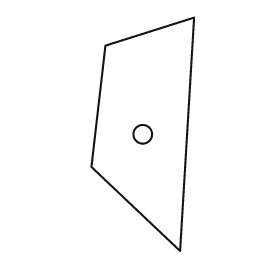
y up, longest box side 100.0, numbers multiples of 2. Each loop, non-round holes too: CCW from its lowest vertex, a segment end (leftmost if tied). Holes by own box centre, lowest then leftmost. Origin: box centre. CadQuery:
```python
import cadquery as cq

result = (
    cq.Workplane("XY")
    .moveTo(16.0, -50.0)
    .lineTo(22.0, 50.0)
    .lineTo(-16.0, 38.0)
    .lineTo(-22.0, -14.0)
    .close()
    .moveTo(0.0, 0.0)
    .circle(4.0)
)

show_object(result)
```